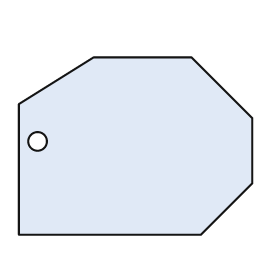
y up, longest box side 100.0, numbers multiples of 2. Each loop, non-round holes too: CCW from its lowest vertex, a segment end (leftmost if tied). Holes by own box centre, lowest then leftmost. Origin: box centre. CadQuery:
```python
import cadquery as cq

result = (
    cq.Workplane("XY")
    .moveTo(-50.0, -38.0)
    .lineTo(28.0, -38.0)
    .lineTo(50.0, -16.0)
    .lineTo(50.0, 12.0)
    .lineTo(24.0, 38.0)
    .lineTo(-18.0, 38.0)
    .lineTo(-50.0, 18.0)
    .close()
    .moveTo(-42.0, 2.0)
    .circle(4.0)
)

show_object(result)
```